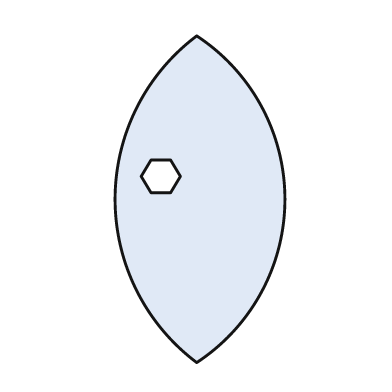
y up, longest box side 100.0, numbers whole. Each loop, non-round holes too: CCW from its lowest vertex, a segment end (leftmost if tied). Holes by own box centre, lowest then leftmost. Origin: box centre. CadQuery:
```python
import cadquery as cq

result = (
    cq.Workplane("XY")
    .moveTo(-1.0, -50.0)
    .threePointArc((26.0, 0.0), (-1.0, 50.0))
    .threePointArc((-26.0, 0.0), (-1.0, -50.0))
    .close()
    .moveTo(-15.0, 2.0)
    .lineTo(-9.0, 2.0)
    .lineTo(-6.0, 7.0)
    .lineTo(-9.0, 12.0)
    .lineTo(-15.0, 12.0)
    .lineTo(-18.0, 7.0)
    .close()
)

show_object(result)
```